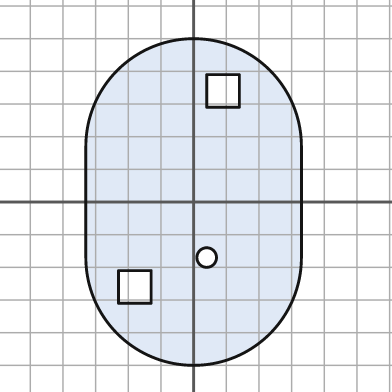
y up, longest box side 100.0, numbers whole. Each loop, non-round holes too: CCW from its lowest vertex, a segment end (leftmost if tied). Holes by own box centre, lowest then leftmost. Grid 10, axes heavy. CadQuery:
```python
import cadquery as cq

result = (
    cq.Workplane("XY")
    .moveTo(-33.0, -17.0)
    .threePointArc((0.0, -50.0), (33.0, -17.0))
    .lineTo(33.0, 17.0)
    .threePointArc((0.0, 50.0), (-33.0, 17.0))
    .close()
    .moveTo(-23.0, -31.0)
    .lineTo(-13.0, -31.0)
    .lineTo(-13.0, -21.0)
    .lineTo(-23.0, -21.0)
    .close()
    .moveTo(4.0, -17.0)
    .circle(3.0)
    .moveTo(4.0, 29.0)
    .lineTo(14.0, 29.0)
    .lineTo(14.0, 39.0)
    .lineTo(4.0, 39.0)
    .close()
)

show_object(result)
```